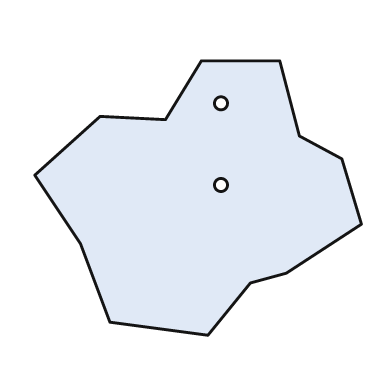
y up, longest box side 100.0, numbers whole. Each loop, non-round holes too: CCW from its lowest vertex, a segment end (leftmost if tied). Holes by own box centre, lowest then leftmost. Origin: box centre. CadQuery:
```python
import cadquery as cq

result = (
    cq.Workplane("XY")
    .moveTo(3.0, -42.0)
    .lineTo(16.0, -26.0)
    .lineTo(27.0, -23.0)
    .lineTo(50.0, -8.0)
    .lineTo(44.0, 12.0)
    .lineTo(31.0, 19.0)
    .lineTo(25.0, 42.0)
    .lineTo(1.0, 42.0)
    .lineTo(-10.0, 24.0)
    .lineTo(-30.0, 25.0)
    .lineTo(-50.0, 7.0)
    .lineTo(-36.0, -14.0)
    .lineTo(-27.0, -38.0)
    .close()
    .moveTo(7.0, 4.0)
    .circle(2.0)
    .moveTo(7.0, 29.0)
    .circle(2.0)
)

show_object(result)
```